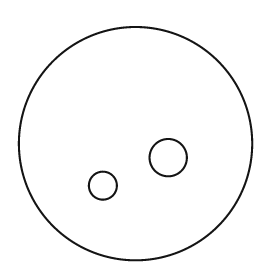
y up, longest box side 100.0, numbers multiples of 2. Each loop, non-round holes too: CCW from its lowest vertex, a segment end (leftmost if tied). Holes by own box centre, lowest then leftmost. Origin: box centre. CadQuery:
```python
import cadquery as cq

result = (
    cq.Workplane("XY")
    .moveTo(0.0, 0.0)
    .circle(50.0)
    .moveTo(-14.0, -18.0)
    .circle(6.0)
    .moveTo(14.0, -6.0)
    .circle(8.0)
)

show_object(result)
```